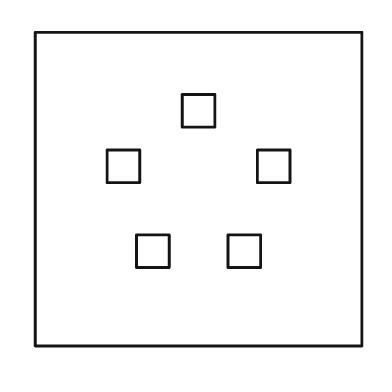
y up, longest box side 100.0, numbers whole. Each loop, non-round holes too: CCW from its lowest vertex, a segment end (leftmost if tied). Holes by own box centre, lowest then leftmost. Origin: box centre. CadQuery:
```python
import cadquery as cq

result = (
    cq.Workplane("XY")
    .moveTo(-50.0, -48.0)
    .lineTo(50.0, -48.0)
    .lineTo(50.0, 48.0)
    .lineTo(-50.0, 48.0)
    .close()
    .moveTo(-19.0, -24.0)
    .lineTo(-9.0, -24.0)
    .lineTo(-9.0, -14.0)
    .lineTo(-19.0, -14.0)
    .close()
    .moveTo(9.0, -24.0)
    .lineTo(19.0, -24.0)
    .lineTo(19.0, -14.0)
    .lineTo(9.0, -14.0)
    .close()
    .moveTo(-28.0, 2.0)
    .lineTo(-18.0, 2.0)
    .lineTo(-18.0, 12.0)
    .lineTo(-28.0, 12.0)
    .close()
    .moveTo(18.0, 2.0)
    .lineTo(28.0, 2.0)
    .lineTo(28.0, 12.0)
    .lineTo(18.0, 12.0)
    .close()
    .moveTo(-5.0, 19.0)
    .lineTo(5.0, 19.0)
    .lineTo(5.0, 29.0)
    .lineTo(-5.0, 29.0)
    .close()
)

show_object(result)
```